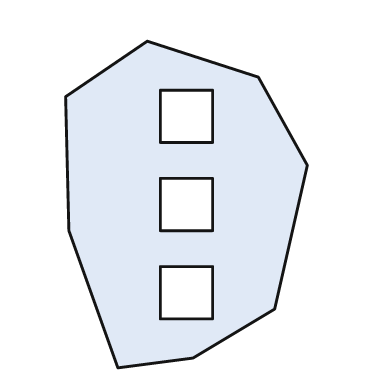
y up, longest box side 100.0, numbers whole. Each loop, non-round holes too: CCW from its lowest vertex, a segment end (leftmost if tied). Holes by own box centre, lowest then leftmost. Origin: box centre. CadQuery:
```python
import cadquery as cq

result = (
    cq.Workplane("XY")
    .moveTo(-21.0, -50.0)
    .lineTo(2.0, -47.0)
    .lineTo(27.0, -32.0)
    .lineTo(37.0, 12.0)
    .lineTo(22.0, 39.0)
    .lineTo(-12.0, 50.0)
    .lineTo(-37.0, 33.0)
    .lineTo(-36.0, -8.0)
    .close()
    .moveTo(-8.0, -35.0)
    .lineTo(8.0, -35.0)
    .lineTo(8.0, -19.0)
    .lineTo(-8.0, -19.0)
    .close()
    .moveTo(-8.0, -8.0)
    .lineTo(8.0, -8.0)
    .lineTo(8.0, 8.0)
    .lineTo(-8.0, 8.0)
    .close()
    .moveTo(-8.0, 19.0)
    .lineTo(8.0, 19.0)
    .lineTo(8.0, 35.0)
    .lineTo(-8.0, 35.0)
    .close()
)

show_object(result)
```